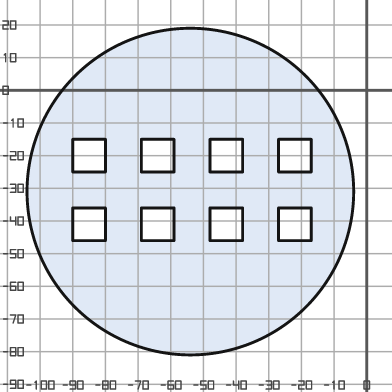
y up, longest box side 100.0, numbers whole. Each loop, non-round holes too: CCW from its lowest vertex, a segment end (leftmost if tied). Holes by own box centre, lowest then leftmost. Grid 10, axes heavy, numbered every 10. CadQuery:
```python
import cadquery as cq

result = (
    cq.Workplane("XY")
    .moveTo(-54.0, -31.0)
    .circle(50.0)
    .moveTo(-90.0, -46.0)
    .lineTo(-80.0, -46.0)
    .lineTo(-80.0, -36.0)
    .lineTo(-90.0, -36.0)
    .close()
    .moveTo(-69.0, -46.0)
    .lineTo(-59.0, -46.0)
    .lineTo(-59.0, -36.0)
    .lineTo(-69.0, -36.0)
    .close()
    .moveTo(-48.0, -46.0)
    .lineTo(-38.0, -46.0)
    .lineTo(-38.0, -36.0)
    .lineTo(-48.0, -36.0)
    .close()
    .moveTo(-27.0, -46.0)
    .lineTo(-17.0, -46.0)
    .lineTo(-17.0, -36.0)
    .lineTo(-27.0, -36.0)
    .close()
    .moveTo(-90.0, -25.0)
    .lineTo(-80.0, -25.0)
    .lineTo(-80.0, -15.0)
    .lineTo(-90.0, -15.0)
    .close()
    .moveTo(-69.0, -25.0)
    .lineTo(-59.0, -25.0)
    .lineTo(-59.0, -15.0)
    .lineTo(-69.0, -15.0)
    .close()
    .moveTo(-48.0, -25.0)
    .lineTo(-38.0, -25.0)
    .lineTo(-38.0, -15.0)
    .lineTo(-48.0, -15.0)
    .close()
    .moveTo(-27.0, -25.0)
    .lineTo(-17.0, -25.0)
    .lineTo(-17.0, -15.0)
    .lineTo(-27.0, -15.0)
    .close()
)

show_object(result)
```